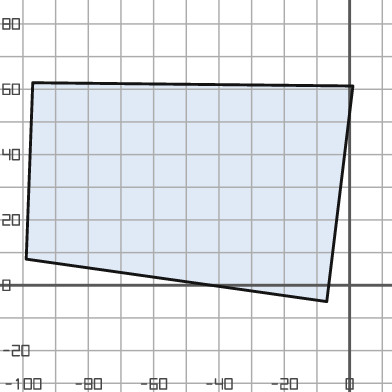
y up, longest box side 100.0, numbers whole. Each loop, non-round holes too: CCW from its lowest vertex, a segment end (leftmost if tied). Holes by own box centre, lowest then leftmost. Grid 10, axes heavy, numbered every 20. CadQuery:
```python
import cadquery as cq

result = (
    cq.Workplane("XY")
    .moveTo(-7.0, -5.0)
    .lineTo(1.0, 61.0)
    .lineTo(-97.0, 62.0)
    .lineTo(-99.0, 8.0)
    .close()
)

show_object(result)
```